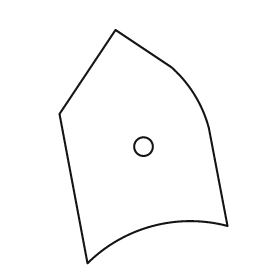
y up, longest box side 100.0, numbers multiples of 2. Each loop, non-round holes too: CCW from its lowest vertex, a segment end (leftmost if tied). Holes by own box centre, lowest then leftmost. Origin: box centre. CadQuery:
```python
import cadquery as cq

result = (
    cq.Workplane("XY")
    .moveTo(-24.0, -50.0)
    .threePointArc((4.0, -34.0), (36.0, -34.0))
    .lineTo(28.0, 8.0)
    .threePointArc((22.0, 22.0), (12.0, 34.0))
    .lineTo(-12.0, 50.0)
    .lineTo(-36.0, 14.0)
    .close()
    .moveTo(0.0, 0.0)
    .circle(4.0)
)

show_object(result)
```